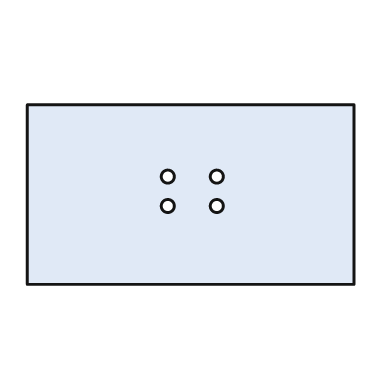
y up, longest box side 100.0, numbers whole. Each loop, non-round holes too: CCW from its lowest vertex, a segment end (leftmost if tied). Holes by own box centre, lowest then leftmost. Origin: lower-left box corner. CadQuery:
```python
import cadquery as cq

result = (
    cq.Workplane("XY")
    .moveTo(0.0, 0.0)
    .lineTo(100.0, 0.0)
    .lineTo(100.0, 55.0)
    .lineTo(0.0, 55.0)
    .close()
    .moveTo(43.0, 24.0)
    .circle(2.0)
    .moveTo(58.0, 24.0)
    .circle(2.0)
    .moveTo(43.0, 33.0)
    .circle(2.0)
    .moveTo(58.0, 33.0)
    .circle(2.0)
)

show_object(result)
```